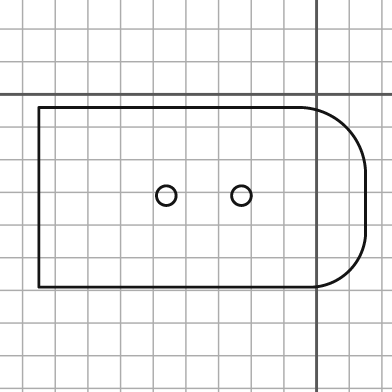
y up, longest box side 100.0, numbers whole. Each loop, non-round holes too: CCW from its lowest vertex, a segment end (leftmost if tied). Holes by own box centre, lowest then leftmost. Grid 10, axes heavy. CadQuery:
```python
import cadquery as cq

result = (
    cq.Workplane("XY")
    .moveTo(-85.0, -59.0)
    .lineTo(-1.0, -59.0)
    .threePointArc((10.0, -54.0), (15.0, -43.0))
    .lineTo(15.0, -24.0)
    .threePointArc((9.0, -10.0), (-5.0, -4.0))
    .lineTo(-85.0, -4.0)
    .close()
    .moveTo(-46.0, -31.0)
    .circle(3.0)
    .moveTo(-23.0, -31.0)
    .circle(3.0)
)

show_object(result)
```